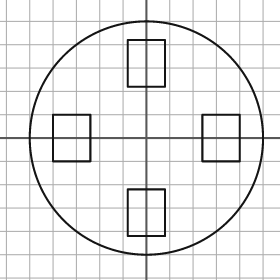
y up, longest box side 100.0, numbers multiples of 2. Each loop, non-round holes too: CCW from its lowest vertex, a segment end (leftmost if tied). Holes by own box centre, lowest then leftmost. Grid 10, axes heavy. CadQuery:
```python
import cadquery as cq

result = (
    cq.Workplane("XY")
    .moveTo(0.0, 0.0)
    .circle(50.0)
    .moveTo(-8.0, -42.0)
    .lineTo(8.0, -42.0)
    .lineTo(8.0, -22.0)
    .lineTo(-8.0, -22.0)
    .close()
    .moveTo(-40.0, -10.0)
    .lineTo(-24.0, -10.0)
    .lineTo(-24.0, 10.0)
    .lineTo(-40.0, 10.0)
    .close()
    .moveTo(24.0, -10.0)
    .lineTo(40.0, -10.0)
    .lineTo(40.0, 10.0)
    .lineTo(24.0, 10.0)
    .close()
    .moveTo(-8.0, 22.0)
    .lineTo(8.0, 22.0)
    .lineTo(8.0, 42.0)
    .lineTo(-8.0, 42.0)
    .close()
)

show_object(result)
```